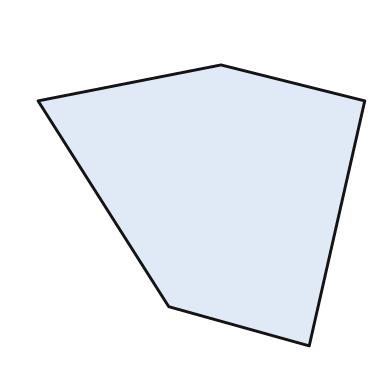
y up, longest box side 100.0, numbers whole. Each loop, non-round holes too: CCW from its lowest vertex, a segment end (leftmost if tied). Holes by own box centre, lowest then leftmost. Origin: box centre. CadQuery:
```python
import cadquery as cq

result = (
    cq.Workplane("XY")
    .moveTo(33.0, -43.0)
    .lineTo(50.0, 32.0)
    .lineTo(6.0, 43.0)
    .lineTo(-50.0, 32.0)
    .lineTo(-10.0, -31.0)
    .close()
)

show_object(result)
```